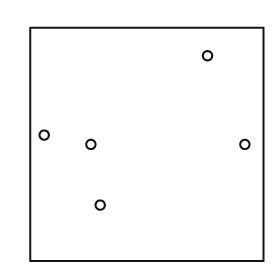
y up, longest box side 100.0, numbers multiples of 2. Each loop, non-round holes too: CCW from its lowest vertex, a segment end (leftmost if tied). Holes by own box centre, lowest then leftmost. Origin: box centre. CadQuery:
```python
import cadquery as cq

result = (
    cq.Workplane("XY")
    .moveTo(-50.0, -50.0)
    .lineTo(50.0, -50.0)
    .lineTo(50.0, 50.0)
    .lineTo(-50.0, 50.0)
    .close()
    .moveTo(-20.0, -26.0)
    .circle(2.0)
    .moveTo(-24.0, 0.0)
    .circle(2.0)
    .moveTo(42.0, 0.0)
    .circle(2.0)
    .moveTo(-44.0, 4.0)
    .circle(2.0)
    .moveTo(26.0, 38.0)
    .circle(2.0)
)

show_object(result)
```